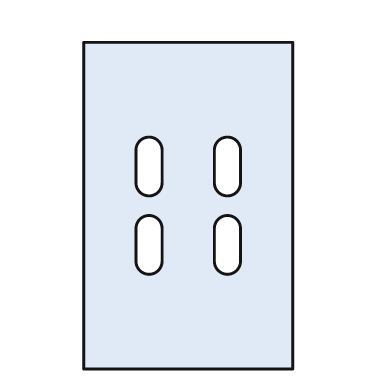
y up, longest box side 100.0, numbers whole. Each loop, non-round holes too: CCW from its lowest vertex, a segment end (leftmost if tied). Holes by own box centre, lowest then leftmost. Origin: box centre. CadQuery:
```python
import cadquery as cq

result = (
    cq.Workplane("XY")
    .moveTo(-32.0, -50.0)
    .lineTo(32.0, -50.0)
    .lineTo(32.0, 50.0)
    .lineTo(-32.0, 50.0)
    .close()
    .moveTo(-16.0, -17.0)
    .threePointArc((-12.0, -21.0), (-8.0, -17.0))
    .lineTo(-8.0, -7.0)
    .threePointArc((-12.0, -3.0), (-16.0, -7.0))
    .close()
    .moveTo(8.0, -17.0)
    .threePointArc((12.0, -21.0), (16.0, -17.0))
    .lineTo(16.0, -7.0)
    .threePointArc((12.0, -3.0), (8.0, -7.0))
    .close()
    .moveTo(-16.0, 7.0)
    .threePointArc((-12.0, 3.0), (-8.0, 7.0))
    .lineTo(-8.0, 17.0)
    .threePointArc((-12.0, 21.0), (-16.0, 17.0))
    .close()
    .moveTo(8.0, 7.0)
    .threePointArc((12.0, 3.0), (16.0, 7.0))
    .lineTo(16.0, 17.0)
    .threePointArc((12.0, 21.0), (8.0, 17.0))
    .close()
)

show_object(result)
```